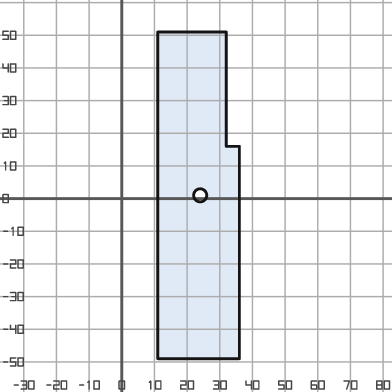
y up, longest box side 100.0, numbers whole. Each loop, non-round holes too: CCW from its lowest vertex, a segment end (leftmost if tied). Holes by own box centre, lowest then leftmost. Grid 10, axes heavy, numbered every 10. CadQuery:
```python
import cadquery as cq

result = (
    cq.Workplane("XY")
    .moveTo(11.0, -49.0)
    .lineTo(36.0, -49.0)
    .lineTo(36.0, 16.0)
    .lineTo(32.0, 16.0)
    .lineTo(32.0, 51.0)
    .lineTo(11.0, 51.0)
    .close()
    .moveTo(24.0, 1.0)
    .circle(2.0)
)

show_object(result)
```